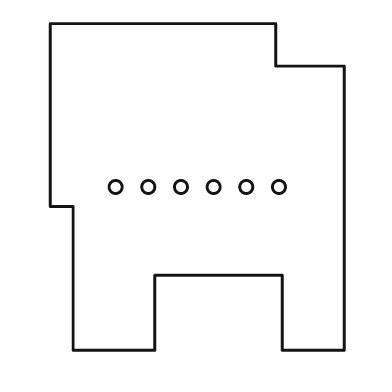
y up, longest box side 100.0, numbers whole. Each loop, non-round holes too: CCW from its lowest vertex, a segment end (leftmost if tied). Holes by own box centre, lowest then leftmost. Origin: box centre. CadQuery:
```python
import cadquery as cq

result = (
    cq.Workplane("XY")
    .moveTo(-38.0, -50.0)
    .lineTo(-13.0, -50.0)
    .lineTo(-13.0, -27.0)
    .lineTo(26.0, -27.0)
    .lineTo(26.0, -50.0)
    .lineTo(45.0, -50.0)
    .lineTo(45.0, 37.0)
    .lineTo(24.0, 37.0)
    .lineTo(24.0, 50.0)
    .lineTo(-45.0, 50.0)
    .lineTo(-45.0, -6.0)
    .lineTo(-38.0, -6.0)
    .close()
    .moveTo(-25.0, 0.0)
    .circle(2.0)
    .moveTo(-15.0, 0.0)
    .circle(2.0)
    .moveTo(-5.0, 0.0)
    .circle(2.0)
    .moveTo(5.0, 0.0)
    .circle(2.0)
    .moveTo(15.0, 0.0)
    .circle(2.0)
    .moveTo(25.0, 0.0)
    .circle(2.0)
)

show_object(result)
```